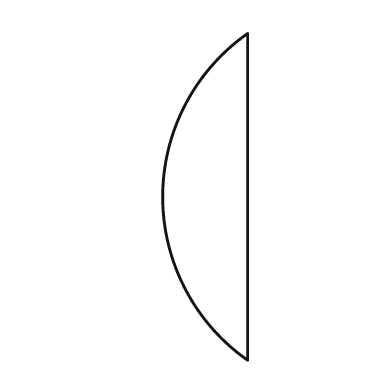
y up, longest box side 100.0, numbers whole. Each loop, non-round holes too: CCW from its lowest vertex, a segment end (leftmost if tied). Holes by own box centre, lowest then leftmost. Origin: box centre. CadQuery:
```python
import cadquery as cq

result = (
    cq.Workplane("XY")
    .moveTo(13.0, -50.0)
    .lineTo(13.0, 50.0)
    .threePointArc((-13.0, 0.0), (13.0, -50.0))
    .close()
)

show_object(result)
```